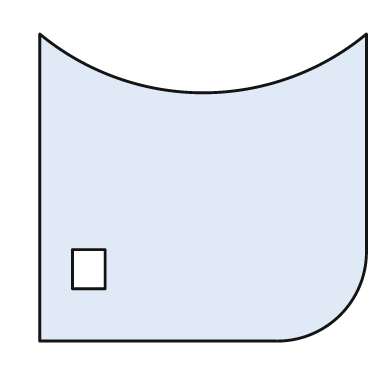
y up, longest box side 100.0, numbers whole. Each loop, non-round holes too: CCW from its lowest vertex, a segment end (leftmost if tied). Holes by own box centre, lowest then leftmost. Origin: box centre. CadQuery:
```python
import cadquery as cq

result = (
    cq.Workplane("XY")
    .moveTo(-50.0, -47.0)
    .lineTo(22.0, -47.0)
    .threePointArc((42.0, -39.0), (50.0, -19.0))
    .lineTo(50.0, 47.0)
    .threePointArc((0.0, 29.0), (-50.0, 47.0))
    .close()
    .moveTo(-40.0, -31.0)
    .lineTo(-30.0, -31.0)
    .lineTo(-30.0, -19.0)
    .lineTo(-40.0, -19.0)
    .close()
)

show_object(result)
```